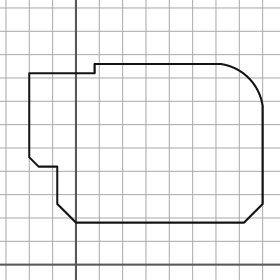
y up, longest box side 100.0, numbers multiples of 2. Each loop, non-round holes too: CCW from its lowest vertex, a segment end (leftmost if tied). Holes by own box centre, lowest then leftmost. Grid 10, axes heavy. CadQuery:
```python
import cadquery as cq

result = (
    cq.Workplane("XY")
    .moveTo(0.0, 18.0)
    .lineTo(72.0, 18.0)
    .lineTo(80.0, 26.0)
    .lineTo(80.0, 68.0)
    .threePointArc((74.0, 80.0), (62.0, 86.0))
    .lineTo(8.0, 86.0)
    .lineTo(8.0, 82.0)
    .lineTo(-20.0, 82.0)
    .lineTo(-20.0, 46.0)
    .lineTo(-16.0, 42.0)
    .lineTo(-8.0, 42.0)
    .lineTo(-8.0, 26.0)
    .close()
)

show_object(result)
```